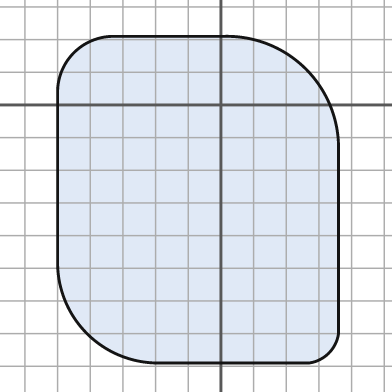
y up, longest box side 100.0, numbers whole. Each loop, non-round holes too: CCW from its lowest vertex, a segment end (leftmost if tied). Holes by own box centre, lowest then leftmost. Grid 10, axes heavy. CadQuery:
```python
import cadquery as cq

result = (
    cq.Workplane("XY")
    .moveTo(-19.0, -79.0)
    .lineTo(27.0, -79.0)
    .threePointArc((33.0, -76.0), (36.0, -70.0))
    .lineTo(36.0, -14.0)
    .threePointArc((26.0, 11.0), (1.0, 21.0))
    .lineTo(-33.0, 21.0)
    .threePointArc((-45.0, 16.0), (-50.0, 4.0))
    .lineTo(-50.0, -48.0)
    .threePointArc((-41.0, -70.0), (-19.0, -79.0))
    .close()
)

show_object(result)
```